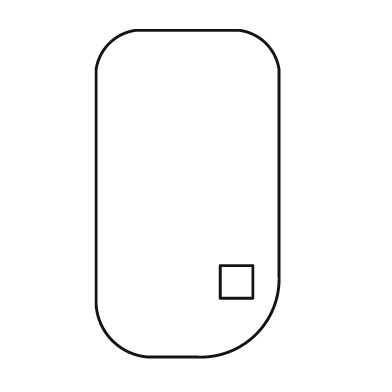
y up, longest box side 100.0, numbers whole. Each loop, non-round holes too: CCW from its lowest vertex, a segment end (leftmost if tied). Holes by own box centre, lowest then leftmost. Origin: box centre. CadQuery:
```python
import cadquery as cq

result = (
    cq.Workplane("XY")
    .moveTo(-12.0, -50.0)
    .lineTo(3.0, -50.0)
    .threePointArc((21.0, -43.0), (28.0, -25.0))
    .lineTo(28.0, 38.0)
    .threePointArc((24.0, 46.0), (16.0, 50.0))
    .lineTo(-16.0, 50.0)
    .threePointArc((-24.0, 46.0), (-28.0, 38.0))
    .lineTo(-28.0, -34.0)
    .threePointArc((-23.0, -45.0), (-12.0, -50.0))
    .close()
    .moveTo(10.0, -32.0)
    .lineTo(20.0, -32.0)
    .lineTo(20.0, -22.0)
    .lineTo(10.0, -22.0)
    .close()
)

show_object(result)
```